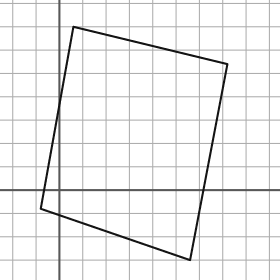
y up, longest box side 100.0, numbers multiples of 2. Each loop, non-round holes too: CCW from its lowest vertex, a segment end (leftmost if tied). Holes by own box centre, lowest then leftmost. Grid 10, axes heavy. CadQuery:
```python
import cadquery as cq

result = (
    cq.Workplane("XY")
    .moveTo(56.0, -30.0)
    .lineTo(72.0, 54.0)
    .lineTo(6.0, 70.0)
    .lineTo(-8.0, -8.0)
    .close()
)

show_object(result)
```